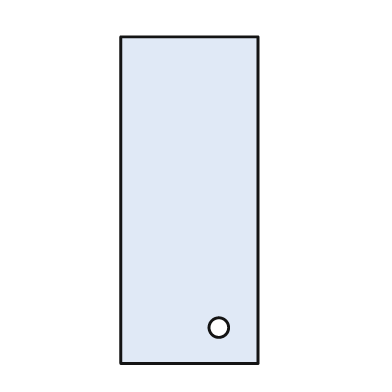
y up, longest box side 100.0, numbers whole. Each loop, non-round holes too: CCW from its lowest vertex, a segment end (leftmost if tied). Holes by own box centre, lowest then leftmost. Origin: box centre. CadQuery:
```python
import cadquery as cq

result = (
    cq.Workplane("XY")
    .moveTo(-21.0, -50.0)
    .lineTo(21.0, -50.0)
    .lineTo(21.0, 50.0)
    .lineTo(-21.0, 50.0)
    .close()
    .moveTo(9.0, -39.0)
    .circle(3.0)
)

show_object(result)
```